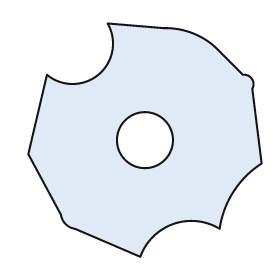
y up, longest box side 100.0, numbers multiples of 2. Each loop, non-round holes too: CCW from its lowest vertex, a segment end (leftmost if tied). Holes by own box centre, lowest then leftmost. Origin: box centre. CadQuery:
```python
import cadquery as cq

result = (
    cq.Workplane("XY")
    .moveTo(-2.0, -50.0)
    .threePointArc((12.0, -36.0), (32.0, -38.0))
    .threePointArc((38.0, -22.0), (50.0, -10.0))
    .lineTo(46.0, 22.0)
    .threePointArc((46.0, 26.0), (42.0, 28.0))
    .lineTo(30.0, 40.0)
    .threePointArc((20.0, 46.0), (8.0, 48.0))
    .lineTo(-16.0, 50.0)
    .threePointArc((-20.0, 28.0), (-42.0, 28.0))
    .lineTo(-50.0, -6.0)
    .lineTo(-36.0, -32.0)
    .threePointArc((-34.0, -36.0), (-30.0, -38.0))
    .close()
    .moveTo(0.0, 0.0)
    .circle(12.0)
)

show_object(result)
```